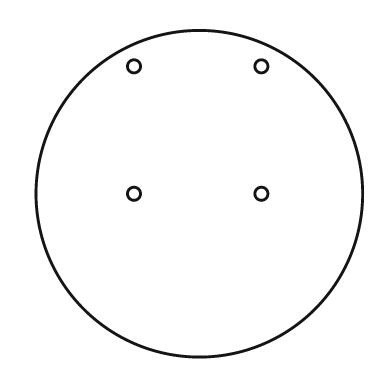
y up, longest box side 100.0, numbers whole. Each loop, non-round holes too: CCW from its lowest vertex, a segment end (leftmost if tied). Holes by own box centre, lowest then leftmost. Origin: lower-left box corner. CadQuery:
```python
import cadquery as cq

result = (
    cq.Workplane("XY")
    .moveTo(50.0, 50.0)
    .circle(50.0)
    .moveTo(30.0, 50.0)
    .circle(2.0)
    .moveTo(69.0, 50.0)
    .circle(2.0)
    .moveTo(30.0, 89.0)
    .circle(2.0)
    .moveTo(69.0, 89.0)
    .circle(2.0)
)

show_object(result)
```